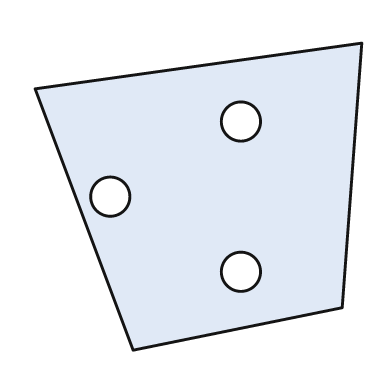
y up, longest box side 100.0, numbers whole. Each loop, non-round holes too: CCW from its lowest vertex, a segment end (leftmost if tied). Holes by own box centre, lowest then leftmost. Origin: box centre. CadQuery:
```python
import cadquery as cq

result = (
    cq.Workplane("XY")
    .moveTo(-20.0, -47.0)
    .lineTo(44.0, -34.0)
    .lineTo(50.0, 47.0)
    .lineTo(-50.0, 33.0)
    .close()
    .moveTo(13.0, -23.0)
    .circle(6.0)
    .moveTo(-27.0, 0.0)
    .circle(6.0)
    .moveTo(13.0, 23.0)
    .circle(6.0)
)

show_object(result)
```